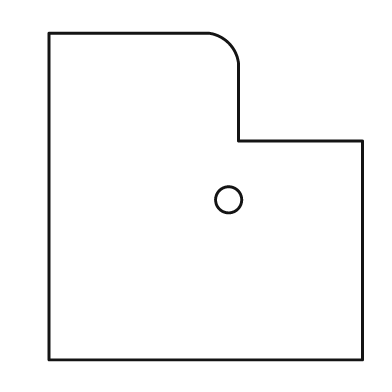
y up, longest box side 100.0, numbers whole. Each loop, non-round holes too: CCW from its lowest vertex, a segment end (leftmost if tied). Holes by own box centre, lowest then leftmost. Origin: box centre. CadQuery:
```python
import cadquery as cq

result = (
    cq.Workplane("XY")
    .moveTo(-48.0, -50.0)
    .lineTo(48.0, -50.0)
    .lineTo(48.0, 17.0)
    .lineTo(10.0, 17.0)
    .lineTo(10.0, 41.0)
    .threePointArc((7.0, 47.0), (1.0, 50.0))
    .lineTo(-48.0, 50.0)
    .close()
    .moveTo(7.0, -1.0)
    .circle(4.0)
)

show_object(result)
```